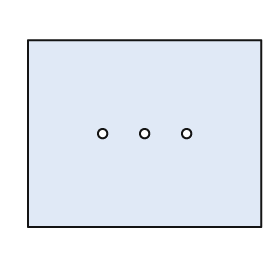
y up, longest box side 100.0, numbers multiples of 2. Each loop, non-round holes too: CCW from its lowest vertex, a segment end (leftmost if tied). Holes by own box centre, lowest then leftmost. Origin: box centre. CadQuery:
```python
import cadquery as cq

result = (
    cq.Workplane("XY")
    .moveTo(-50.0, -40.0)
    .lineTo(50.0, -40.0)
    .lineTo(50.0, 40.0)
    .lineTo(-50.0, 40.0)
    .close()
    .moveTo(-18.0, 0.0)
    .circle(2.0)
    .moveTo(0.0, 0.0)
    .circle(2.0)
    .moveTo(18.0, 0.0)
    .circle(2.0)
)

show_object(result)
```